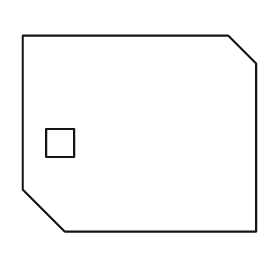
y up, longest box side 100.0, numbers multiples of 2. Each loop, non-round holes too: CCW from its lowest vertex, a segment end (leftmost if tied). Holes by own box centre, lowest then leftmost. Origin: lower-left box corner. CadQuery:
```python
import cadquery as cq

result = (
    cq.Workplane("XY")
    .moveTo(18.0, 0.0)
    .lineTo(100.0, 0.0)
    .lineTo(100.0, 72.0)
    .lineTo(88.0, 84.0)
    .lineTo(0.0, 84.0)
    .lineTo(0.0, 18.0)
    .close()
    .moveTo(10.0, 32.0)
    .lineTo(22.0, 32.0)
    .lineTo(22.0, 44.0)
    .lineTo(10.0, 44.0)
    .close()
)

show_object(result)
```